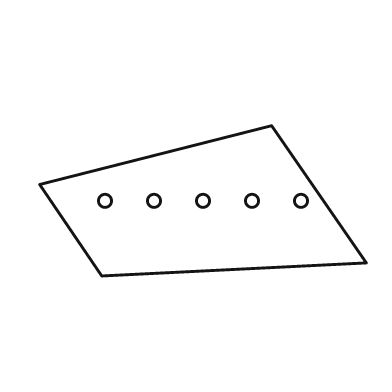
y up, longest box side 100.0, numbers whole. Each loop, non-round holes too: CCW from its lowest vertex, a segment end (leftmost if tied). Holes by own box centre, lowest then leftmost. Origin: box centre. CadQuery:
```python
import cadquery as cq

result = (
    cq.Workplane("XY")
    .moveTo(-31.0, -23.0)
    .lineTo(50.0, -19.0)
    .lineTo(21.0, 23.0)
    .lineTo(-50.0, 5.0)
    .close()
    .moveTo(-30.0, 0.0)
    .circle(2.0)
    .moveTo(-15.0, 0.0)
    .circle(2.0)
    .moveTo(0.0, 0.0)
    .circle(2.0)
    .moveTo(15.0, 0.0)
    .circle(2.0)
    .moveTo(30.0, 0.0)
    .circle(2.0)
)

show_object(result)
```